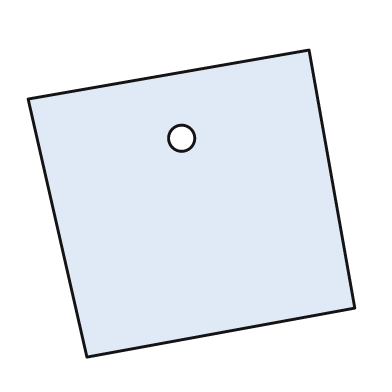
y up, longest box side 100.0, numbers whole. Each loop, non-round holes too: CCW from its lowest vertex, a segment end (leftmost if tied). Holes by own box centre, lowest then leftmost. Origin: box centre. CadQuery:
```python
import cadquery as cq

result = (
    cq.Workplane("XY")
    .moveTo(-32.0, -47.0)
    .lineTo(50.0, -32.0)
    .lineTo(36.0, 47.0)
    .lineTo(-50.0, 32.0)
    .close()
    .moveTo(-3.0, 20.0)
    .circle(4.0)
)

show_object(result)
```